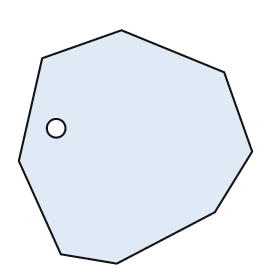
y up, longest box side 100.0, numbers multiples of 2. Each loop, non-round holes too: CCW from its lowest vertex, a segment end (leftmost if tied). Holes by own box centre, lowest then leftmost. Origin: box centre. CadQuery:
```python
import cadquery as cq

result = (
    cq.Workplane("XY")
    .moveTo(-8.0, -50.0)
    .lineTo(34.0, -28.0)
    .lineTo(50.0, -2.0)
    .lineTo(38.0, 32.0)
    .lineTo(-6.0, 50.0)
    .lineTo(-40.0, 38.0)
    .lineTo(-50.0, -6.0)
    .lineTo(-32.0, -46.0)
    .close()
    .moveTo(-34.0, 8.0)
    .circle(4.0)
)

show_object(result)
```